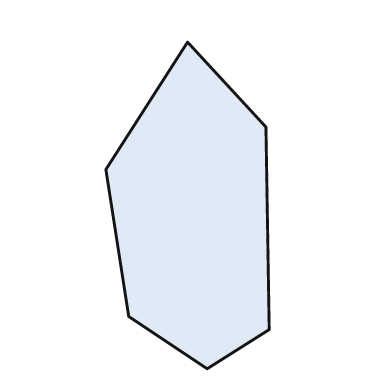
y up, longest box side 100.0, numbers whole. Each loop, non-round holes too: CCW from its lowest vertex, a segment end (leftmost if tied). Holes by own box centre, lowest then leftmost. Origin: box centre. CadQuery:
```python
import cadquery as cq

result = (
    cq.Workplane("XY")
    .moveTo(6.0, -50.0)
    .lineTo(25.0, -38.0)
    .lineTo(24.0, 24.0)
    .lineTo(0.0, 50.0)
    .lineTo(-25.0, 11.0)
    .lineTo(-18.0, -34.0)
    .close()
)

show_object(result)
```